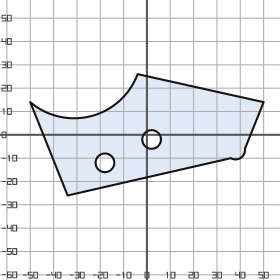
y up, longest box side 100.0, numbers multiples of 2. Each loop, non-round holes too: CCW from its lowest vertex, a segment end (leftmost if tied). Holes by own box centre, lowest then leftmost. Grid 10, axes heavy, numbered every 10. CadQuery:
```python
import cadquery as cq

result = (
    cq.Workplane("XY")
    .moveTo(-34.0, -26.0)
    .lineTo(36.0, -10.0)
    .threePointArc((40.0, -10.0), (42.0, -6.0))
    .lineTo(50.0, 14.0)
    .lineTo(-4.0, 26.0)
    .threePointArc((-24.0, 8.0), (-50.0, 14.0))
    .close()
    .moveTo(-18.0, -12.0)
    .circle(4.0)
    .moveTo(2.0, -2.0)
    .circle(4.0)
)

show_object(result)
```